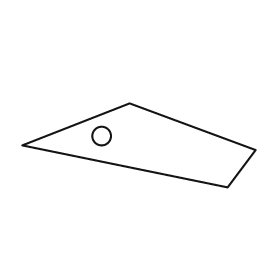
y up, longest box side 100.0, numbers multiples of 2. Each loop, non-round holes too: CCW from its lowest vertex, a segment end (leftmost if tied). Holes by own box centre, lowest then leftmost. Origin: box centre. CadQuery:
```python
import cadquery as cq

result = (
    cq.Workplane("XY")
    .moveTo(38.0, -18.0)
    .lineTo(50.0, -2.0)
    .lineTo(-4.0, 18.0)
    .lineTo(-50.0, 0.0)
    .close()
    .moveTo(-16.0, 4.0)
    .circle(4.0)
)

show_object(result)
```